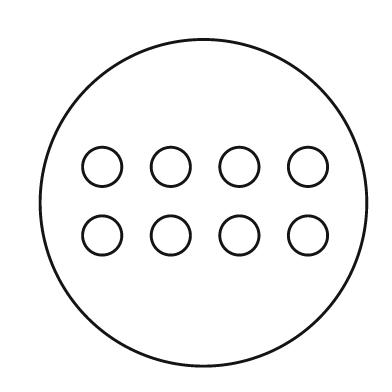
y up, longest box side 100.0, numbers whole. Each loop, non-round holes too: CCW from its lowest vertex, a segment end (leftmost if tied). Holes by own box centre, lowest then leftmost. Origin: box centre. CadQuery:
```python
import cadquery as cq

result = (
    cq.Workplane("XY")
    .moveTo(0.0, 0.0)
    .circle(50.0)
    .moveTo(-31.0, -10.0)
    .circle(6.0)
    .moveTo(-10.0, -10.0)
    .circle(6.0)
    .moveTo(11.0, -10.0)
    .circle(6.0)
    .moveTo(32.0, -10.0)
    .circle(6.0)
    .moveTo(-31.0, 11.0)
    .circle(6.0)
    .moveTo(-10.0, 11.0)
    .circle(6.0)
    .moveTo(11.0, 11.0)
    .circle(6.0)
    .moveTo(32.0, 11.0)
    .circle(6.0)
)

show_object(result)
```